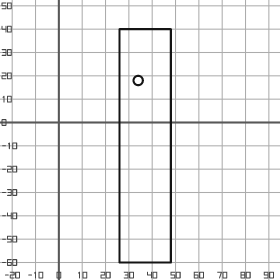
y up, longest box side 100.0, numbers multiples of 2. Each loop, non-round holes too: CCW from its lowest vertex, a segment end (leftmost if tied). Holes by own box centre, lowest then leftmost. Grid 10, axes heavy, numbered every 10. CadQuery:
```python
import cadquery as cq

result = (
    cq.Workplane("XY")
    .moveTo(26.0, -60.0)
    .lineTo(48.0, -60.0)
    .lineTo(48.0, 40.0)
    .lineTo(26.0, 40.0)
    .close()
    .moveTo(34.0, 18.0)
    .circle(2.0)
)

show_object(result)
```